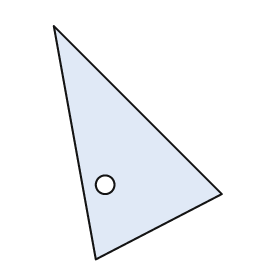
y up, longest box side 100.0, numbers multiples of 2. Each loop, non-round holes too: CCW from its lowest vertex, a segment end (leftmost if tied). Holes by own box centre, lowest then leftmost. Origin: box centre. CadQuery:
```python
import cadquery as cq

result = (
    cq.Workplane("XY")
    .moveTo(-18.0, -50.0)
    .lineTo(36.0, -22.0)
    .lineTo(-36.0, 50.0)
    .close()
    .moveTo(-14.0, -18.0)
    .circle(4.0)
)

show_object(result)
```